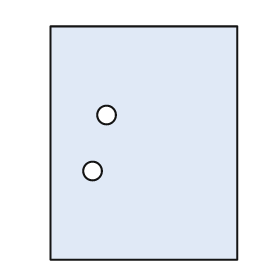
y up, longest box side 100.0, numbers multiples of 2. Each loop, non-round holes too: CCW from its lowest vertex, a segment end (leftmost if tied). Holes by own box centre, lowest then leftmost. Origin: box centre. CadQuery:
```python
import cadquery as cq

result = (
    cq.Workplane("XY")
    .moveTo(-40.0, -50.0)
    .lineTo(40.0, -50.0)
    .lineTo(40.0, 50.0)
    .lineTo(-40.0, 50.0)
    .close()
    .moveTo(-22.0, -12.0)
    .circle(4.0)
    .moveTo(-16.0, 12.0)
    .circle(4.0)
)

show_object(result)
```